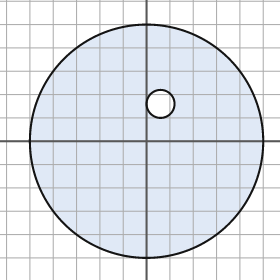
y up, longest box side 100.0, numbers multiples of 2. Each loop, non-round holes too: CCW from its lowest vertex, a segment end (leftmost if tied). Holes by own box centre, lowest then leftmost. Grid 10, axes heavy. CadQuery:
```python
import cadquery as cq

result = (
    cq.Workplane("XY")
    .moveTo(0.0, 0.0)
    .circle(50.0)
    .moveTo(6.0, 16.0)
    .circle(6.0)
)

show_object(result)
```